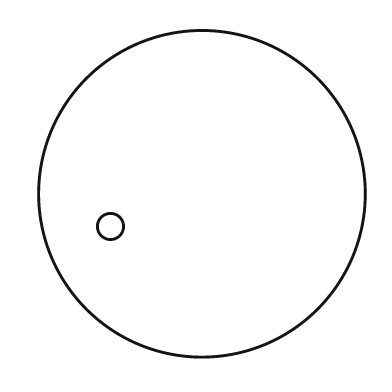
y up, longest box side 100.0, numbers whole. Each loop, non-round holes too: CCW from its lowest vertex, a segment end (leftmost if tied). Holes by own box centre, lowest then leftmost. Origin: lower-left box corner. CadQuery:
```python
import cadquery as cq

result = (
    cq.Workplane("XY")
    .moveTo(50.0, 50.0)
    .circle(50.0)
    .moveTo(22.0, 40.0)
    .circle(4.0)
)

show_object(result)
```